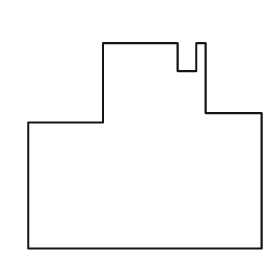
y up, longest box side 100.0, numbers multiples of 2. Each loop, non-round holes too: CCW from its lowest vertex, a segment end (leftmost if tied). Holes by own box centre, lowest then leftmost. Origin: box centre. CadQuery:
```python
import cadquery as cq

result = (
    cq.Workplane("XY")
    .moveTo(-50.0, -44.0)
    .lineTo(50.0, -44.0)
    .lineTo(50.0, 14.0)
    .lineTo(26.0, 14.0)
    .lineTo(26.0, 44.0)
    .lineTo(22.0, 44.0)
    .lineTo(22.0, 32.0)
    .lineTo(14.0, 32.0)
    .lineTo(14.0, 44.0)
    .lineTo(-18.0, 44.0)
    .lineTo(-18.0, 10.0)
    .lineTo(-50.0, 10.0)
    .close()
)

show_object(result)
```